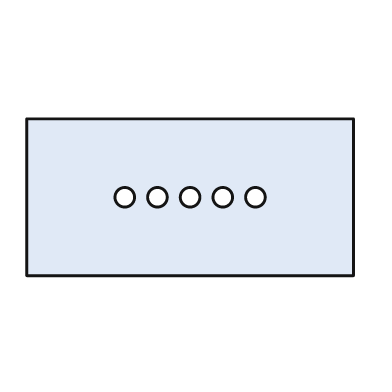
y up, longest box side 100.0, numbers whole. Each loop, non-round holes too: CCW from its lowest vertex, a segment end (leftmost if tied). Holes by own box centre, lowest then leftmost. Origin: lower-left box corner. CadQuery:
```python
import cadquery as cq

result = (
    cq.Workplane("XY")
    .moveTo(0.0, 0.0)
    .lineTo(100.0, 0.0)
    .lineTo(100.0, 48.0)
    .lineTo(0.0, 48.0)
    .close()
    .moveTo(30.0, 24.0)
    .circle(3.0)
    .moveTo(40.0, 24.0)
    .circle(3.0)
    .moveTo(50.0, 24.0)
    .circle(3.0)
    .moveTo(60.0, 24.0)
    .circle(3.0)
    .moveTo(70.0, 24.0)
    .circle(3.0)
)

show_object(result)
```